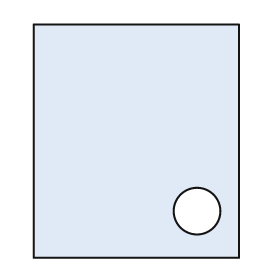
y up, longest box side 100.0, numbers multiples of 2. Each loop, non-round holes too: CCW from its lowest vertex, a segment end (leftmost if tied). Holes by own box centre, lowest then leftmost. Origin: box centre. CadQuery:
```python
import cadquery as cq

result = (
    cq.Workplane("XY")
    .moveTo(-44.0, -50.0)
    .lineTo(44.0, -50.0)
    .lineTo(44.0, 50.0)
    .lineTo(-44.0, 50.0)
    .close()
    .moveTo(26.0, -30.0)
    .circle(10.0)
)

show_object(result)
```